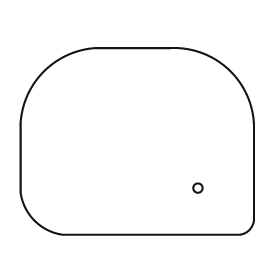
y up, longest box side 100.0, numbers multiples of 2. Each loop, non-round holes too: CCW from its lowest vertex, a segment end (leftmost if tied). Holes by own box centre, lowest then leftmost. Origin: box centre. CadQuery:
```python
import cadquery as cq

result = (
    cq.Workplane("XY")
    .moveTo(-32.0, -40.0)
    .lineTo(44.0, -40.0)
    .threePointArc((48.0, -38.0), (50.0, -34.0))
    .lineTo(50.0, 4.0)
    .threePointArc((40.0, 30.0), (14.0, 40.0))
    .lineTo(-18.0, 40.0)
    .threePointArc((-40.0, 30.0), (-50.0, 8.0))
    .lineTo(-50.0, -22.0)
    .threePointArc((-44.0, -34.0), (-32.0, -40.0))
    .close()
    .moveTo(26.0, -20.0)
    .circle(2.0)
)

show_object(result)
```